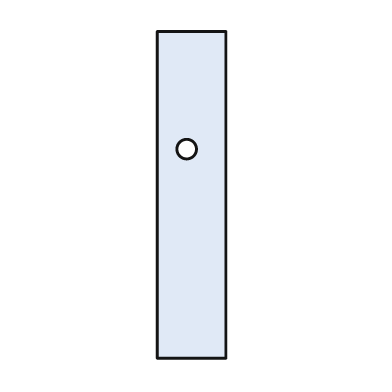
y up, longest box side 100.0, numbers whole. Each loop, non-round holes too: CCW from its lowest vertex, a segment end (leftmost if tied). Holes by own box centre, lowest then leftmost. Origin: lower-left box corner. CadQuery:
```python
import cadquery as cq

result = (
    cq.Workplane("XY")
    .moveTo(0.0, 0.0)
    .lineTo(21.0, 0.0)
    .lineTo(21.0, 100.0)
    .lineTo(0.0, 100.0)
    .close()
    .moveTo(9.0, 64.0)
    .circle(3.0)
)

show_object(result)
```